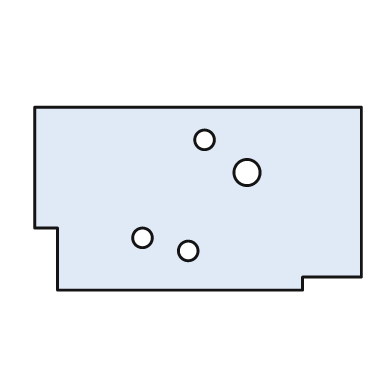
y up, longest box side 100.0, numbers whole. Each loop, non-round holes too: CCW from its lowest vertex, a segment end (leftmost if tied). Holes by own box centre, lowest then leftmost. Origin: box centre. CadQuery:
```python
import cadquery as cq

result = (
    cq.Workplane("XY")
    .moveTo(-43.0, -28.0)
    .lineTo(32.0, -28.0)
    .lineTo(32.0, -24.0)
    .lineTo(50.0, -24.0)
    .lineTo(50.0, 28.0)
    .lineTo(-50.0, 28.0)
    .lineTo(-50.0, -9.0)
    .lineTo(-43.0, -9.0)
    .close()
    .moveTo(-3.0, -16.0)
    .circle(3.0)
    .moveTo(-17.0, -12.0)
    .circle(3.0)
    .moveTo(15.0, 8.0)
    .circle(4.0)
    .moveTo(2.0, 18.0)
    .circle(3.0)
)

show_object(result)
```